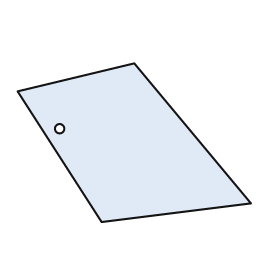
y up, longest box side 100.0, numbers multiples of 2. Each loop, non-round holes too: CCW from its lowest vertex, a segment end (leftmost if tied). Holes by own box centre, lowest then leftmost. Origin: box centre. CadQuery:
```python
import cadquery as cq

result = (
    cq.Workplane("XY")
    .moveTo(-14.0, -34.0)
    .lineTo(50.0, -26.0)
    .lineTo(0.0, 34.0)
    .lineTo(-50.0, 22.0)
    .close()
    .moveTo(-32.0, 6.0)
    .circle(2.0)
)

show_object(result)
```